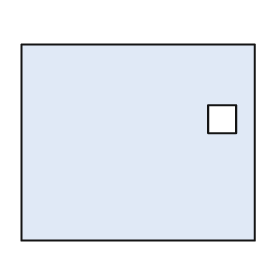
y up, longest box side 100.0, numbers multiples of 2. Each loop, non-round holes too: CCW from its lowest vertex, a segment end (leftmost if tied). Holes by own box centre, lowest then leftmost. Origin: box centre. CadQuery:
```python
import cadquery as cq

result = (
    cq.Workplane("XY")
    .moveTo(-50.0, -42.0)
    .lineTo(50.0, -42.0)
    .lineTo(50.0, 42.0)
    .lineTo(-50.0, 42.0)
    .close()
    .moveTo(30.0, 4.0)
    .lineTo(42.0, 4.0)
    .lineTo(42.0, 16.0)
    .lineTo(30.0, 16.0)
    .close()
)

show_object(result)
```